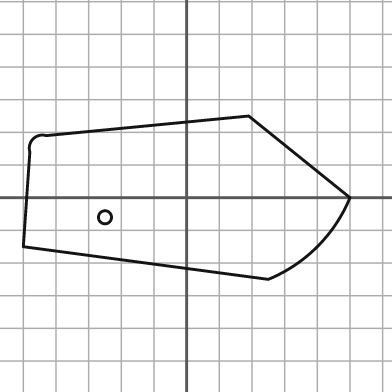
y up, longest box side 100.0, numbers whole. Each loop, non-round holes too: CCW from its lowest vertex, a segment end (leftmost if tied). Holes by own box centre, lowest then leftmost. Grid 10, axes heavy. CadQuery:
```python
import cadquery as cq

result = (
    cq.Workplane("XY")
    .moveTo(25.0, -25.0)
    .threePointArc((40.0, -15.0), (50.0, 0.0))
    .lineTo(19.0, 25.0)
    .lineTo(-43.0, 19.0)
    .threePointArc((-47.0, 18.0), (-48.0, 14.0))
    .lineTo(-50.0, -15.0)
    .close()
    .moveTo(-25.0, -6.0)
    .circle(2.0)
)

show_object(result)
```